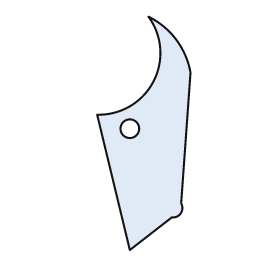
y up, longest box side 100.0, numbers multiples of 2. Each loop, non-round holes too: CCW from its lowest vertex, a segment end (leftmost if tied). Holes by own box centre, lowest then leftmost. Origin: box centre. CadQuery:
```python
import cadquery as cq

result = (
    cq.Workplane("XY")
    .moveTo(-6.0, -50.0)
    .lineTo(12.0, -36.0)
    .threePointArc((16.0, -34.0), (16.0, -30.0))
    .lineTo(20.0, 26.0)
    .threePointArc((14.0, 40.0), (2.0, 50.0))
    .threePointArc((4.0, 22.0), (-20.0, 8.0))
    .close()
    .moveTo(-6.0, 2.0)
    .circle(4.0)
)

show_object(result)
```